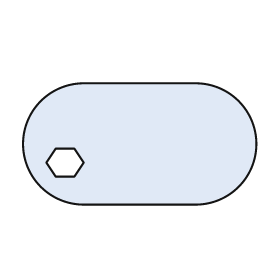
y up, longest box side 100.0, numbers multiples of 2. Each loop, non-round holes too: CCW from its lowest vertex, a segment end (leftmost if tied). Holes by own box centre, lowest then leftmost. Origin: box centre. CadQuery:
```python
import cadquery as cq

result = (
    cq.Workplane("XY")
    .moveTo(-24.0, -26.0)
    .lineTo(24.0, -26.0)
    .threePointArc((50.0, 0.0), (24.0, 26.0))
    .lineTo(-24.0, 26.0)
    .threePointArc((-50.0, 0.0), (-24.0, -26.0))
    .close()
    .moveTo(-36.0, -14.0)
    .lineTo(-28.0, -14.0)
    .lineTo(-24.0, -8.0)
    .lineTo(-28.0, -2.0)
    .lineTo(-36.0, -2.0)
    .lineTo(-40.0, -8.0)
    .close()
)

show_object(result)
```